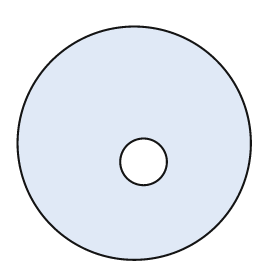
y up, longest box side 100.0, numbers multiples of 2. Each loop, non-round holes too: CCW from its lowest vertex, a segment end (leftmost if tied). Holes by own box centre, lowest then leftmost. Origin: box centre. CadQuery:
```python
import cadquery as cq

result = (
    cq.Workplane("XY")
    .moveTo(0.0, 0.0)
    .circle(50.0)
    .moveTo(4.0, -8.0)
    .circle(10.0)
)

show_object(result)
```